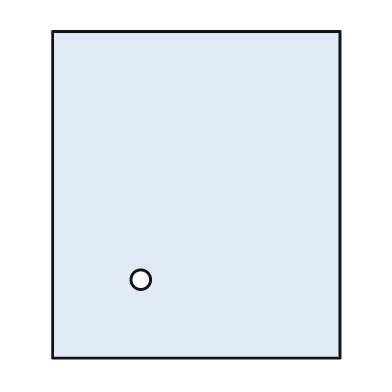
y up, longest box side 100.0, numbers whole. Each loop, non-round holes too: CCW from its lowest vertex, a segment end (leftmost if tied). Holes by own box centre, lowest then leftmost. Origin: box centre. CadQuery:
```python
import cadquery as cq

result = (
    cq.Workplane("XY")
    .moveTo(-44.0, -50.0)
    .lineTo(44.0, -50.0)
    .lineTo(44.0, 50.0)
    .lineTo(-44.0, 50.0)
    .close()
    .moveTo(-17.0, -26.0)
    .circle(3.0)
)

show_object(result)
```